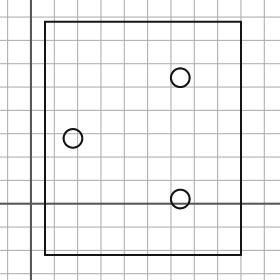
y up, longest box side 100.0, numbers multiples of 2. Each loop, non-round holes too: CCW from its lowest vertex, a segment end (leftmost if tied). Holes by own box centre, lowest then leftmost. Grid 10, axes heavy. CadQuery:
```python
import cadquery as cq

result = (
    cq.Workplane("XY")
    .moveTo(6.0, -22.0)
    .lineTo(90.0, -22.0)
    .lineTo(90.0, 78.0)
    .lineTo(6.0, 78.0)
    .close()
    .moveTo(64.0, 2.0)
    .circle(4.0)
    .moveTo(18.0, 28.0)
    .circle(4.0)
    .moveTo(64.0, 54.0)
    .circle(4.0)
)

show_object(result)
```